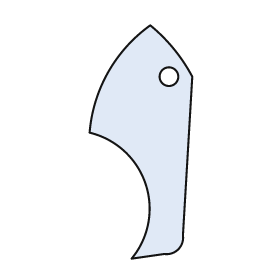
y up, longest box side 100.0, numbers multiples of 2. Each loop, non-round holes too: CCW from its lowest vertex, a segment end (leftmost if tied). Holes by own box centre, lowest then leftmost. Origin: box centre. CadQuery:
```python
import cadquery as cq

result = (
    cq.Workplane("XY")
    .moveTo(-4.0, -50.0)
    .lineTo(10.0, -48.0)
    .threePointArc((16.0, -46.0), (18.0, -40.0))
    .lineTo(22.0, 28.0)
    .threePointArc((14.0, 40.0), (4.0, 50.0))
    .threePointArc((-14.0, 30.0), (-22.0, 4.0))
    .threePointArc((2.0, -18.0), (-4.0, -50.0))
    .close()
    .moveTo(12.0, 28.0)
    .circle(4.0)
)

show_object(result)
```